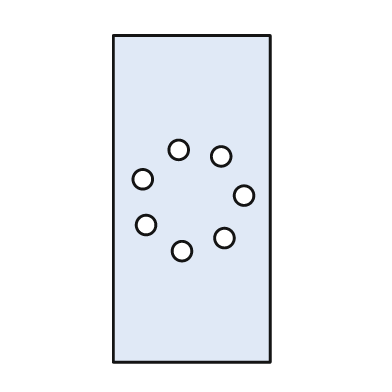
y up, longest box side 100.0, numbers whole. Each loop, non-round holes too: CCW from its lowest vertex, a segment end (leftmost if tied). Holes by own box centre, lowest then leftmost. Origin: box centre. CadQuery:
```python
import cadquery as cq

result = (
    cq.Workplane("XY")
    .moveTo(-24.0, -50.0)
    .lineTo(24.0, -50.0)
    .lineTo(24.0, 50.0)
    .lineTo(-24.0, 50.0)
    .close()
    .moveTo(-3.0, -16.0)
    .circle(3.0)
    .moveTo(10.0, -12.0)
    .circle(3.0)
    .moveTo(-14.0, -8.0)
    .circle(3.0)
    .moveTo(16.0, 1.0)
    .circle(3.0)
    .moveTo(-15.0, 6.0)
    .circle(3.0)
    .moveTo(9.0, 13.0)
    .circle(3.0)
    .moveTo(-4.0, 15.0)
    .circle(3.0)
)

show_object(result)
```